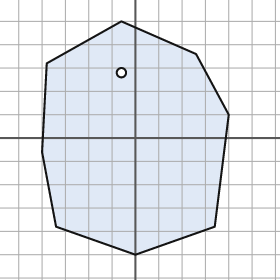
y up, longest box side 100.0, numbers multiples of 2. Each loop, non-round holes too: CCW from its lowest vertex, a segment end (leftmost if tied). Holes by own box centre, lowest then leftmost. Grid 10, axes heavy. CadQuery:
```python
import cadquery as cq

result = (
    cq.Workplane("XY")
    .moveTo(0.0, -50.0)
    .lineTo(34.0, -38.0)
    .lineTo(40.0, 10.0)
    .lineTo(26.0, 36.0)
    .lineTo(-6.0, 50.0)
    .lineTo(-38.0, 32.0)
    .lineTo(-40.0, -6.0)
    .lineTo(-34.0, -38.0)
    .close()
    .moveTo(-6.0, 28.0)
    .circle(2.0)
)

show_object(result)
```